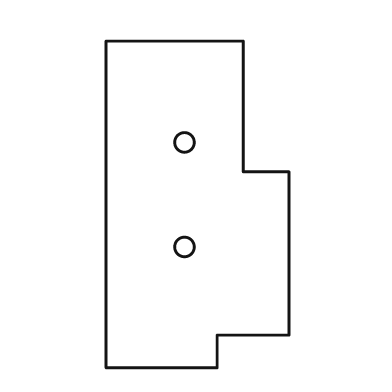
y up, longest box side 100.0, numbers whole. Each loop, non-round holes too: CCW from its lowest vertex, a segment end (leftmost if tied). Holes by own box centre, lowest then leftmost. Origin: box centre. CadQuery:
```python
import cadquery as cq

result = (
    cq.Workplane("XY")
    .moveTo(-28.0, -50.0)
    .lineTo(6.0, -50.0)
    .lineTo(6.0, -40.0)
    .lineTo(28.0, -40.0)
    .lineTo(28.0, 10.0)
    .lineTo(14.0, 10.0)
    .lineTo(14.0, 50.0)
    .lineTo(-28.0, 50.0)
    .close()
    .moveTo(-4.0, -13.0)
    .circle(3.0)
    .moveTo(-4.0, 19.0)
    .circle(3.0)
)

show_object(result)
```